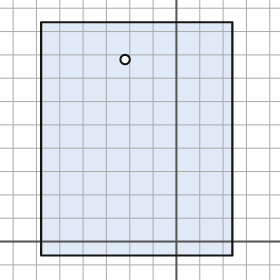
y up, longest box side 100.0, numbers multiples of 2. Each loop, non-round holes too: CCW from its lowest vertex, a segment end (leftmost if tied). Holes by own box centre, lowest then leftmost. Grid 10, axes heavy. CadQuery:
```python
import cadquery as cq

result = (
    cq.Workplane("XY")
    .moveTo(-58.0, -6.0)
    .lineTo(24.0, -6.0)
    .lineTo(24.0, 94.0)
    .lineTo(-58.0, 94.0)
    .close()
    .moveTo(-22.0, 78.0)
    .circle(2.0)
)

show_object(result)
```